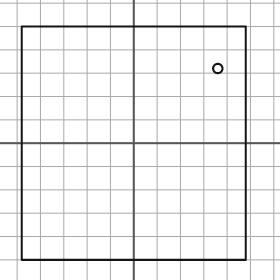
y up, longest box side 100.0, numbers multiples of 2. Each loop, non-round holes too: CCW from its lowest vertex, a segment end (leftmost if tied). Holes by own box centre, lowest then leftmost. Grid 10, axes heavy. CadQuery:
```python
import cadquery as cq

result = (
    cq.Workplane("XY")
    .moveTo(-48.0, -50.0)
    .lineTo(48.0, -50.0)
    .lineTo(48.0, 50.0)
    .lineTo(-48.0, 50.0)
    .close()
    .moveTo(36.0, 32.0)
    .circle(2.0)
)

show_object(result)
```